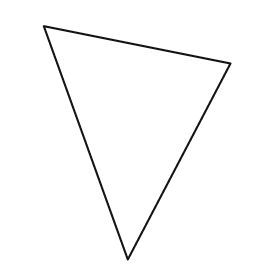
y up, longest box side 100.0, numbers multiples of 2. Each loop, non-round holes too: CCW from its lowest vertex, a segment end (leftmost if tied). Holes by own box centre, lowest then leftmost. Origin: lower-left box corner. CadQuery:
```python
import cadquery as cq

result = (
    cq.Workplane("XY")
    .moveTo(36.0, 0.0)
    .lineTo(80.0, 84.0)
    .lineTo(0.0, 100.0)
    .close()
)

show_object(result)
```